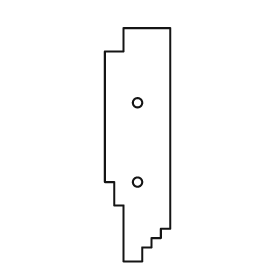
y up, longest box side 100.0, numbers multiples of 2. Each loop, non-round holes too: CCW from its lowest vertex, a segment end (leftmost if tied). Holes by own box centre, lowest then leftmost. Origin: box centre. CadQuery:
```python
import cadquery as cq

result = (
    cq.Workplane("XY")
    .moveTo(-6.0, -50.0)
    .lineTo(2.0, -50.0)
    .lineTo(2.0, -44.0)
    .lineTo(6.0, -44.0)
    .lineTo(6.0, -40.0)
    .lineTo(10.0, -40.0)
    .lineTo(10.0, -36.0)
    .lineTo(14.0, -36.0)
    .lineTo(14.0, 50.0)
    .lineTo(-6.0, 50.0)
    .lineTo(-6.0, 40.0)
    .lineTo(-14.0, 40.0)
    .lineTo(-14.0, -16.0)
    .lineTo(-10.0, -16.0)
    .lineTo(-10.0, -26.0)
    .lineTo(-6.0, -26.0)
    .close()
    .moveTo(0.0, -16.0)
    .circle(2.0)
    .moveTo(0.0, 18.0)
    .circle(2.0)
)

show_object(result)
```